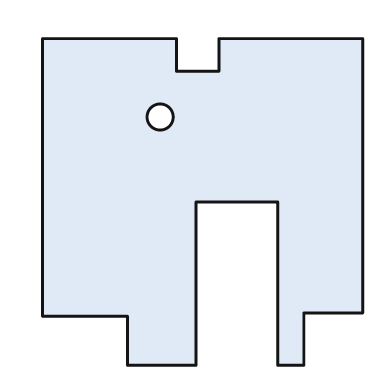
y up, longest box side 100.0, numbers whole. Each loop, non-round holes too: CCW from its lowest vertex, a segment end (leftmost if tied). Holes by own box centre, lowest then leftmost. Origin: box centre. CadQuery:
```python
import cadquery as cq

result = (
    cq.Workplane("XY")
    .moveTo(-23.0, -50.0)
    .lineTo(-2.0, -50.0)
    .lineTo(-2.0, 0.0)
    .lineTo(23.0, 0.0)
    .lineTo(23.0, -50.0)
    .lineTo(31.0, -50.0)
    .lineTo(31.0, -34.0)
    .lineTo(49.0, -34.0)
    .lineTo(49.0, 50.0)
    .lineTo(5.0, 50.0)
    .lineTo(5.0, 40.0)
    .lineTo(-8.0, 40.0)
    .lineTo(-8.0, 50.0)
    .lineTo(-49.0, 50.0)
    .lineTo(-49.0, -35.0)
    .lineTo(-23.0, -35.0)
    .close()
    .moveTo(-13.0, 26.0)
    .circle(4.0)
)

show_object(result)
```